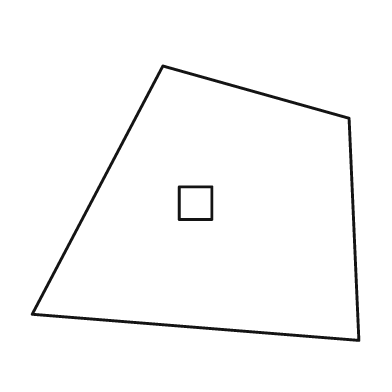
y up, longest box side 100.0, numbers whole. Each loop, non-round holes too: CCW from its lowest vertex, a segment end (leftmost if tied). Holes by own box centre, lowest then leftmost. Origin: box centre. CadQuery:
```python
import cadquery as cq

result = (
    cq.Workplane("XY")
    .moveTo(50.0, -42.0)
    .lineTo(47.0, 26.0)
    .lineTo(-10.0, 42.0)
    .lineTo(-50.0, -34.0)
    .close()
    .moveTo(-5.0, -5.0)
    .lineTo(5.0, -5.0)
    .lineTo(5.0, 5.0)
    .lineTo(-5.0, 5.0)
    .close()
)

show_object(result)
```